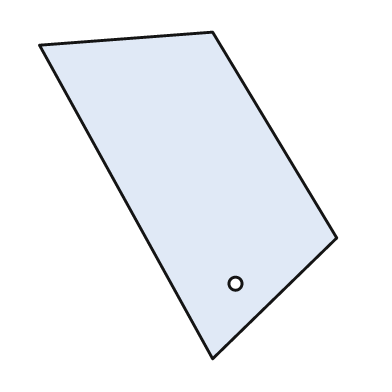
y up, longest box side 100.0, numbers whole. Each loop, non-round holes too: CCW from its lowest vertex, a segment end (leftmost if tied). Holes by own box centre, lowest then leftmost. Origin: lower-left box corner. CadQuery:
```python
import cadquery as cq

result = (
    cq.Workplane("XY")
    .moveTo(53.0, 0.0)
    .lineTo(91.0, 37.0)
    .lineTo(53.0, 100.0)
    .lineTo(0.0, 96.0)
    .close()
    .moveTo(60.0, 23.0)
    .circle(2.0)
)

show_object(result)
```